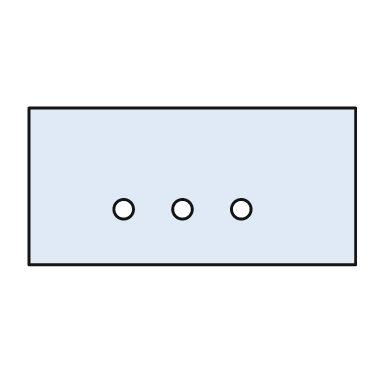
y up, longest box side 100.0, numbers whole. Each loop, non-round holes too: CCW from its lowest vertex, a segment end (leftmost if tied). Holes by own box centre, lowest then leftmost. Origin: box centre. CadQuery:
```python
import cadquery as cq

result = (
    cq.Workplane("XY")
    .moveTo(-50.0, -24.0)
    .lineTo(50.0, -24.0)
    .lineTo(50.0, 24.0)
    .lineTo(-50.0, 24.0)
    .close()
    .moveTo(-21.0, -7.0)
    .circle(3.0)
    .moveTo(-3.0, -7.0)
    .circle(3.0)
    .moveTo(15.0, -7.0)
    .circle(3.0)
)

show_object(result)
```